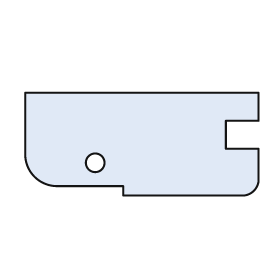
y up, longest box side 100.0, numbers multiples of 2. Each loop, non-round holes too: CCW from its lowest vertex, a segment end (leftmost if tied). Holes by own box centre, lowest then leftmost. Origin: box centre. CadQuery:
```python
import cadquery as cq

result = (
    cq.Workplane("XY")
    .moveTo(-8.0, -22.0)
    .lineTo(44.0, -22.0)
    .threePointArc((48.0, -20.0), (50.0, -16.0))
    .lineTo(50.0, -2.0)
    .lineTo(36.0, -2.0)
    .lineTo(36.0, 10.0)
    .lineTo(50.0, 10.0)
    .lineTo(50.0, 22.0)
    .lineTo(-50.0, 22.0)
    .lineTo(-50.0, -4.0)
    .threePointArc((-46.0, -14.0), (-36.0, -18.0))
    .lineTo(-8.0, -18.0)
    .close()
    .moveTo(-20.0, -8.0)
    .circle(4.0)
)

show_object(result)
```